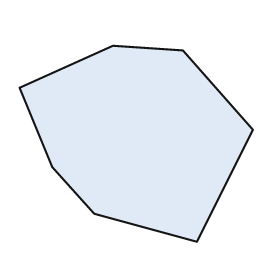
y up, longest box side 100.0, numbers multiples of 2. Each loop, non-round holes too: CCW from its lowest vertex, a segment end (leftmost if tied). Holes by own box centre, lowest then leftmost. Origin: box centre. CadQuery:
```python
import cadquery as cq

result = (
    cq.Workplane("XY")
    .moveTo(26.0, -42.0)
    .lineTo(50.0, 6.0)
    .lineTo(20.0, 40.0)
    .lineTo(-10.0, 42.0)
    .lineTo(-50.0, 24.0)
    .lineTo(-36.0, -10.0)
    .lineTo(-18.0, -30.0)
    .close()
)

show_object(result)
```